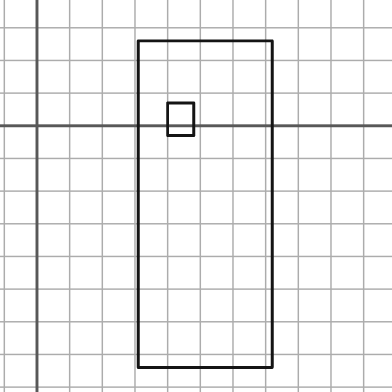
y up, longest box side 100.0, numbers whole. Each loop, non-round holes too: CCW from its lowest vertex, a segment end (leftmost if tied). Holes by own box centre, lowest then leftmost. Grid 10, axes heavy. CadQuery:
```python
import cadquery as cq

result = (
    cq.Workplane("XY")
    .moveTo(31.0, -74.0)
    .lineTo(72.0, -74.0)
    .lineTo(72.0, 26.0)
    .lineTo(31.0, 26.0)
    .close()
    .moveTo(40.0, -3.0)
    .lineTo(48.0, -3.0)
    .lineTo(48.0, 7.0)
    .lineTo(40.0, 7.0)
    .close()
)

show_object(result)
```